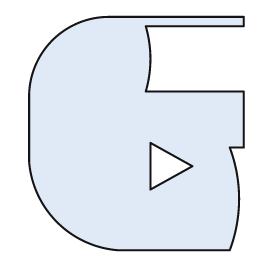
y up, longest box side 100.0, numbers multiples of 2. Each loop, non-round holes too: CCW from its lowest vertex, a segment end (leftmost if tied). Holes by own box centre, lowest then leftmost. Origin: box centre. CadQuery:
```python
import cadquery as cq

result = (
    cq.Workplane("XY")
    .moveTo(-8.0, -50.0)
    .lineTo(40.0, -50.0)
    .threePointArc((44.0, -28.0), (40.0, -6.0))
    .lineTo(46.0, -6.0)
    .lineTo(46.0, 18.0)
    .lineTo(4.0, 18.0)
    .threePointArc((6.0, 32.0), (4.0, 46.0))
    .lineTo(46.0, 46.0)
    .lineTo(46.0, 50.0)
    .lineTo(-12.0, 50.0)
    .threePointArc((-36.0, 40.0), (-46.0, 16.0))
    .lineTo(-46.0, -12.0)
    .threePointArc((-34.0, -38.0), (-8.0, -50.0))
    .close()
    .moveTo(6.0, -24.0)
    .lineTo(24.0, -14.0)
    .lineTo(6.0, -4.0)
    .close()
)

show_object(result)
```